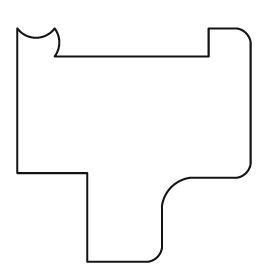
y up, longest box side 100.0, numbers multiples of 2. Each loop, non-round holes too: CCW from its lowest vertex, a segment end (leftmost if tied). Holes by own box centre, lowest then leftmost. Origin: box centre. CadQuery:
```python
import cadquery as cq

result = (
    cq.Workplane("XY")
    .moveTo(-20.0, -50.0)
    .lineTo(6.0, -50.0)
    .threePointArc((10.0, -48.0), (12.0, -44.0))
    .lineTo(12.0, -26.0)
    .threePointArc((16.0, -18.0), (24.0, -14.0))
    .lineTo(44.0, -14.0)
    .threePointArc((48.0, -12.0), (50.0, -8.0))
    .lineTo(50.0, 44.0)
    .threePointArc((48.0, 48.0), (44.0, 50.0))
    .lineTo(32.0, 50.0)
    .lineTo(32.0, 38.0)
    .lineTo(-34.0, 38.0)
    .threePointArc((-32.0, 44.0), (-34.0, 50.0))
    .threePointArc((-42.0, 46.0), (-50.0, 50.0))
    .lineTo(-50.0, -12.0)
    .lineTo(-20.0, -12.0)
    .close()
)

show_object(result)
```